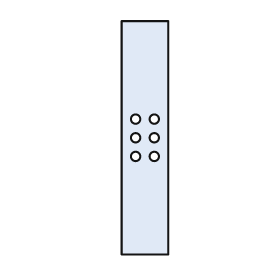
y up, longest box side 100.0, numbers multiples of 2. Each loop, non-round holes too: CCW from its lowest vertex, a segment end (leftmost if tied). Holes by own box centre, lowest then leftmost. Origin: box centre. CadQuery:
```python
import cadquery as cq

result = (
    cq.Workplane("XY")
    .moveTo(-10.0, -50.0)
    .lineTo(10.0, -50.0)
    .lineTo(10.0, 50.0)
    .lineTo(-10.0, 50.0)
    .close()
    .moveTo(-4.0, -8.0)
    .circle(2.0)
    .moveTo(4.0, -8.0)
    .circle(2.0)
    .moveTo(-4.0, 0.0)
    .circle(2.0)
    .moveTo(4.0, 0.0)
    .circle(2.0)
    .moveTo(-4.0, 8.0)
    .circle(2.0)
    .moveTo(4.0, 8.0)
    .circle(2.0)
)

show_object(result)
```